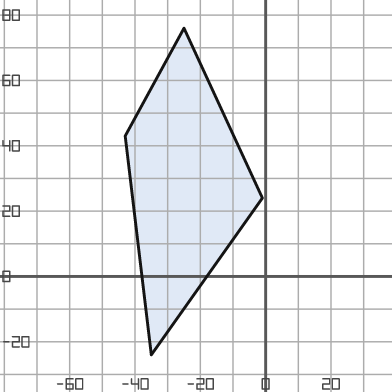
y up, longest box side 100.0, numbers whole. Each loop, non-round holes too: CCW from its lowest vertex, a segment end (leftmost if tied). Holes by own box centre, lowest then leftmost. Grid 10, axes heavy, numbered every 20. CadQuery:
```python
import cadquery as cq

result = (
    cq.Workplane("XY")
    .moveTo(-35.0, -24.0)
    .lineTo(-1.0, 24.0)
    .lineTo(-25.0, 76.0)
    .lineTo(-43.0, 43.0)
    .close()
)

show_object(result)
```